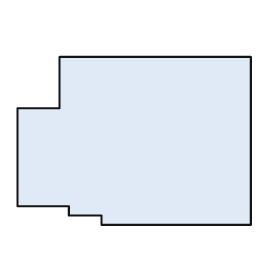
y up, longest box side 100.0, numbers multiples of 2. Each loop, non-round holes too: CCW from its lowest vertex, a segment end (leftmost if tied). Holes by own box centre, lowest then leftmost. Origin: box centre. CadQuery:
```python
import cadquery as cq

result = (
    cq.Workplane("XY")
    .moveTo(-14.0, -36.0)
    .lineTo(50.0, -36.0)
    .lineTo(50.0, 36.0)
    .lineTo(-32.0, 36.0)
    .lineTo(-32.0, 14.0)
    .lineTo(-50.0, 14.0)
    .lineTo(-50.0, -28.0)
    .lineTo(-28.0, -28.0)
    .lineTo(-28.0, -32.0)
    .lineTo(-14.0, -32.0)
    .close()
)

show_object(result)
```